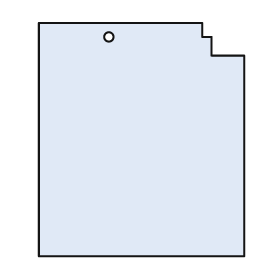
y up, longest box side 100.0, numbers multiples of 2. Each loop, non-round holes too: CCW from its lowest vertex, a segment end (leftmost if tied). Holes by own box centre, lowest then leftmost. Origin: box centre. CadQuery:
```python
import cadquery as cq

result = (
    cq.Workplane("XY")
    .moveTo(-44.0, -50.0)
    .lineTo(44.0, -50.0)
    .lineTo(44.0, 36.0)
    .lineTo(30.0, 36.0)
    .lineTo(30.0, 44.0)
    .lineTo(26.0, 44.0)
    .lineTo(26.0, 50.0)
    .lineTo(-44.0, 50.0)
    .close()
    .moveTo(-14.0, 44.0)
    .circle(2.0)
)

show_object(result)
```